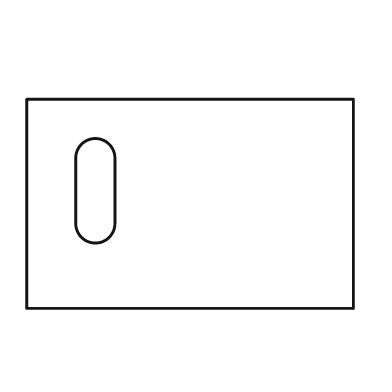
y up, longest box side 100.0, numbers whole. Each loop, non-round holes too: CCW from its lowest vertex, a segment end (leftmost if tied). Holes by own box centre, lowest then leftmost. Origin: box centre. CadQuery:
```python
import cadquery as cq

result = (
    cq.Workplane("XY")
    .moveTo(-50.0, -32.0)
    .lineTo(50.0, -32.0)
    .lineTo(50.0, 32.0)
    .lineTo(-50.0, 32.0)
    .close()
    .moveTo(-35.0, -6.0)
    .threePointArc((-29.0, -12.0), (-23.0, -6.0))
    .lineTo(-23.0, 14.0)
    .threePointArc((-29.0, 20.0), (-35.0, 14.0))
    .close()
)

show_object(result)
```